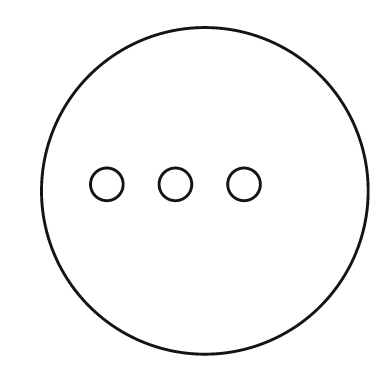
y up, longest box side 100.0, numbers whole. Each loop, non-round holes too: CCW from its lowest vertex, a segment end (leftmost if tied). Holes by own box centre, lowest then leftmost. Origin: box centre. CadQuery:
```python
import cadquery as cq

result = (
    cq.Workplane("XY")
    .moveTo(0.0, 0.0)
    .circle(50.0)
    .moveTo(-30.0, 2.0)
    .circle(5.0)
    .moveTo(-9.0, 2.0)
    .circle(5.0)
    .moveTo(12.0, 2.0)
    .circle(5.0)
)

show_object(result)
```